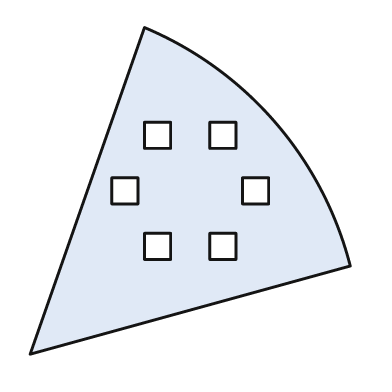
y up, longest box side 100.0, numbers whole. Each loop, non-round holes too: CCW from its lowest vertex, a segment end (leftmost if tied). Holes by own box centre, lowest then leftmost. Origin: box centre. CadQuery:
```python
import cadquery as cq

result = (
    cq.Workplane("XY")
    .moveTo(-49.0, -50.0)
    .lineTo(49.0, -23.0)
    .threePointArc((26.0, 21.0), (-14.0, 50.0))
    .close()
    .moveTo(-14.0, -21.0)
    .lineTo(-6.0, -21.0)
    .lineTo(-6.0, -13.0)
    .lineTo(-14.0, -13.0)
    .close()
    .moveTo(6.0, -21.0)
    .lineTo(14.0, -21.0)
    .lineTo(14.0, -13.0)
    .lineTo(6.0, -13.0)
    .close()
    .moveTo(-24.0, -4.0)
    .lineTo(-16.0, -4.0)
    .lineTo(-16.0, 4.0)
    .lineTo(-24.0, 4.0)
    .close()
    .moveTo(16.0, -4.0)
    .lineTo(24.0, -4.0)
    .lineTo(24.0, 4.0)
    .lineTo(16.0, 4.0)
    .close()
    .moveTo(-14.0, 13.0)
    .lineTo(-6.0, 13.0)
    .lineTo(-6.0, 21.0)
    .lineTo(-14.0, 21.0)
    .close()
    .moveTo(6.0, 13.0)
    .lineTo(14.0, 13.0)
    .lineTo(14.0, 21.0)
    .lineTo(6.0, 21.0)
    .close()
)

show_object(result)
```